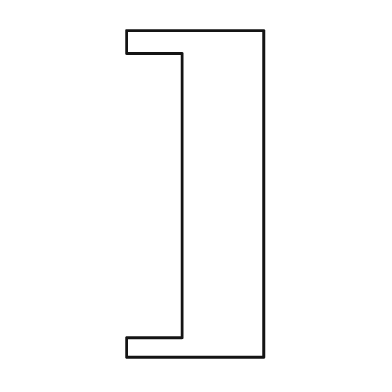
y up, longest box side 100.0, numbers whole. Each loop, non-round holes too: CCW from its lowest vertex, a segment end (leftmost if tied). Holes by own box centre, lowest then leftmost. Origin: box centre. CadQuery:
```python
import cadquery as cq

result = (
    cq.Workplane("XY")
    .moveTo(-21.0, -50.0)
    .lineTo(21.0, -50.0)
    .lineTo(21.0, 50.0)
    .lineTo(-21.0, 50.0)
    .lineTo(-21.0, 43.0)
    .lineTo(-4.0, 43.0)
    .lineTo(-4.0, -44.0)
    .lineTo(-21.0, -44.0)
    .close()
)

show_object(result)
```